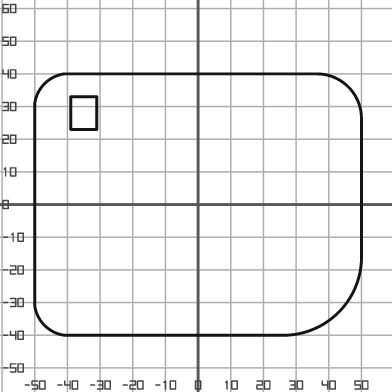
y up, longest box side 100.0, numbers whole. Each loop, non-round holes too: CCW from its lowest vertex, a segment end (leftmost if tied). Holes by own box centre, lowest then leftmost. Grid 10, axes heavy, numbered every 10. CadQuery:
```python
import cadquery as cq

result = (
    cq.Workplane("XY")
    .moveTo(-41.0, -40.0)
    .lineTo(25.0, -40.0)
    .threePointArc((43.0, -33.0), (50.0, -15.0))
    .lineTo(50.0, 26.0)
    .threePointArc((46.0, 36.0), (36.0, 40.0))
    .lineTo(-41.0, 40.0)
    .threePointArc((-47.0, 37.0), (-50.0, 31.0))
    .lineTo(-50.0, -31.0)
    .threePointArc((-47.0, -37.0), (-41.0, -40.0))
    .close()
    .moveTo(-39.0, 23.0)
    .lineTo(-31.0, 23.0)
    .lineTo(-31.0, 33.0)
    .lineTo(-39.0, 33.0)
    .close()
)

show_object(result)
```